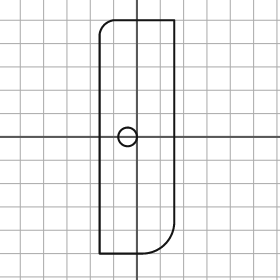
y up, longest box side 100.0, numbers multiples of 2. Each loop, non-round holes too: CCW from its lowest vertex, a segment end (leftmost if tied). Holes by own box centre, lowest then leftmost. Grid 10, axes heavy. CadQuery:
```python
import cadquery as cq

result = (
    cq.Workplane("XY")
    .moveTo(-16.0, -50.0)
    .lineTo(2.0, -50.0)
    .threePointArc((12.0, -46.0), (16.0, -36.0))
    .lineTo(16.0, 50.0)
    .lineTo(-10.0, 50.0)
    .threePointArc((-14.0, 48.0), (-16.0, 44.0))
    .close()
    .moveTo(-4.0, 0.0)
    .circle(4.0)
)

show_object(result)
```